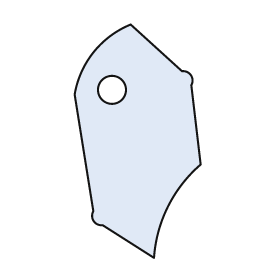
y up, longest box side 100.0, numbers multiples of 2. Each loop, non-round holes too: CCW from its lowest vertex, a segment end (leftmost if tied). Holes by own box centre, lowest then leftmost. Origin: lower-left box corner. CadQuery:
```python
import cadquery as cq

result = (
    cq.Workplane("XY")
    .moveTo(34.0, 0.0)
    .threePointArc((40.0, 22.0), (54.0, 40.0))
    .lineTo(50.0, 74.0)
    .threePointArc((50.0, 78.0), (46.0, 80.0))
    .lineTo(24.0, 100.0)
    .threePointArc((8.0, 88.0), (0.0, 70.0))
    .lineTo(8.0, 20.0)
    .threePointArc((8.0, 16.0), (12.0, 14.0))
    .close()
    .moveTo(16.0, 72.0)
    .circle(6.0)
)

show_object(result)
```